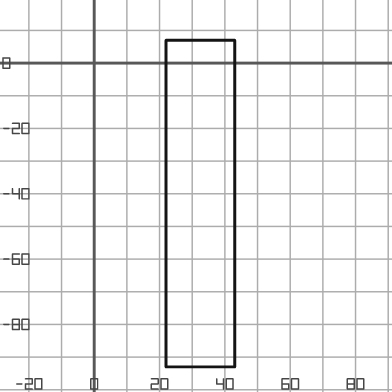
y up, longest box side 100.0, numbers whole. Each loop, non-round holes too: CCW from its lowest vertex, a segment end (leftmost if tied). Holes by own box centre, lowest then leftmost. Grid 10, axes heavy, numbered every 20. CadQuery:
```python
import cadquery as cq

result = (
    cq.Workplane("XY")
    .moveTo(22.0, -93.0)
    .lineTo(43.0, -93.0)
    .lineTo(43.0, 7.0)
    .lineTo(22.0, 7.0)
    .close()
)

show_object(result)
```